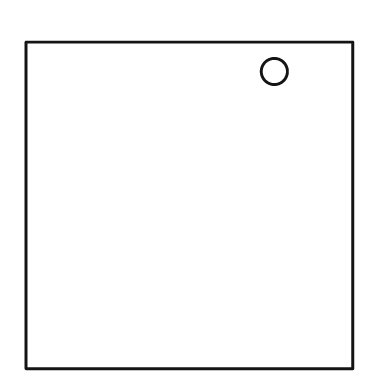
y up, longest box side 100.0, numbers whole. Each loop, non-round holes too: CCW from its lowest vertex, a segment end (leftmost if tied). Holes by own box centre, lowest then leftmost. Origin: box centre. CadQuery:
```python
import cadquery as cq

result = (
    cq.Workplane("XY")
    .moveTo(-50.0, -50.0)
    .lineTo(50.0, -50.0)
    .lineTo(50.0, 50.0)
    .lineTo(-50.0, 50.0)
    .close()
    .moveTo(26.0, 41.0)
    .circle(4.0)
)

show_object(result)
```